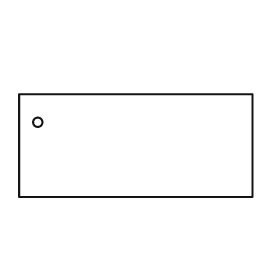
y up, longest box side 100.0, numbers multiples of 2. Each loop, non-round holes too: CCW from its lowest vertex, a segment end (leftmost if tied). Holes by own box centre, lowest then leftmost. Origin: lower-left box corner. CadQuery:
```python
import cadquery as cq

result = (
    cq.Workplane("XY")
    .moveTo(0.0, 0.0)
    .lineTo(100.0, 0.0)
    .lineTo(100.0, 44.0)
    .lineTo(0.0, 44.0)
    .close()
    .moveTo(8.0, 32.0)
    .circle(2.0)
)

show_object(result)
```